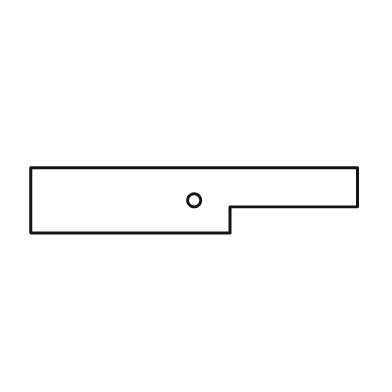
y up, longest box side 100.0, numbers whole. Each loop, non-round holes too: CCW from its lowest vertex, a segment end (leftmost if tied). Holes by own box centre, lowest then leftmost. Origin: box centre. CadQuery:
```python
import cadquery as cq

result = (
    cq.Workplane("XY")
    .moveTo(-50.0, -10.0)
    .lineTo(11.0, -10.0)
    .lineTo(11.0, -2.0)
    .lineTo(50.0, -2.0)
    .lineTo(50.0, 10.0)
    .lineTo(-50.0, 10.0)
    .close()
    .moveTo(0.0, 0.0)
    .circle(2.0)
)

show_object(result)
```